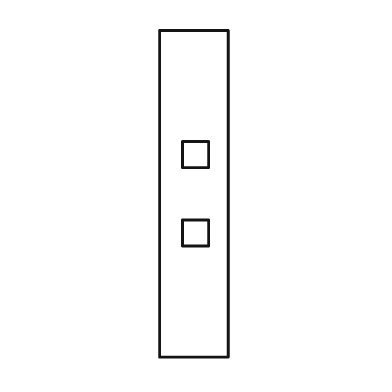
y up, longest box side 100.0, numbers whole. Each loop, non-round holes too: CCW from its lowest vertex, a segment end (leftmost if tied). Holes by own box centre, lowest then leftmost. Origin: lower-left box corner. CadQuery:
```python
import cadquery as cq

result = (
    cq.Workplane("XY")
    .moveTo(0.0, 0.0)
    .lineTo(21.0, 0.0)
    .lineTo(21.0, 100.0)
    .lineTo(0.0, 100.0)
    .close()
    .moveTo(7.0, 34.0)
    .lineTo(15.0, 34.0)
    .lineTo(15.0, 42.0)
    .lineTo(7.0, 42.0)
    .close()
    .moveTo(7.0, 58.0)
    .lineTo(15.0, 58.0)
    .lineTo(15.0, 66.0)
    .lineTo(7.0, 66.0)
    .close()
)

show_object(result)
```